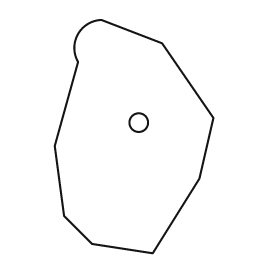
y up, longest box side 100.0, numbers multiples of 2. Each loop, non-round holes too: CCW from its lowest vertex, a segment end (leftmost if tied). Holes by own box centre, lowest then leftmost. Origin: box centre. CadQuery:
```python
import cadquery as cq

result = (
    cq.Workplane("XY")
    .moveTo(8.0, -50.0)
    .lineTo(28.0, -18.0)
    .lineTo(34.0, 8.0)
    .lineTo(12.0, 40.0)
    .lineTo(-14.0, 50.0)
    .threePointArc((-24.0, 44.0), (-24.0, 32.0))
    .lineTo(-34.0, -4.0)
    .lineTo(-30.0, -34.0)
    .lineTo(-18.0, -46.0)
    .close()
    .moveTo(2.0, 6.0)
    .circle(4.0)
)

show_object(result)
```